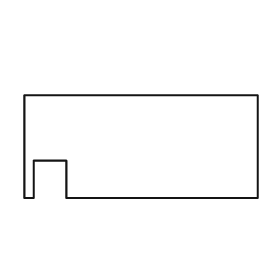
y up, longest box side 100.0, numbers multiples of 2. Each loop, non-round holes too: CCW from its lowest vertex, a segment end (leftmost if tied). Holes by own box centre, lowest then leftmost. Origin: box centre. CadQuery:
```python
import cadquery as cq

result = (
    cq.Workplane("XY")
    .moveTo(-50.0, -22.0)
    .lineTo(-46.0, -22.0)
    .lineTo(-46.0, -6.0)
    .lineTo(-32.0, -6.0)
    .lineTo(-32.0, -22.0)
    .lineTo(50.0, -22.0)
    .lineTo(50.0, 22.0)
    .lineTo(-50.0, 22.0)
    .close()
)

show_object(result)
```